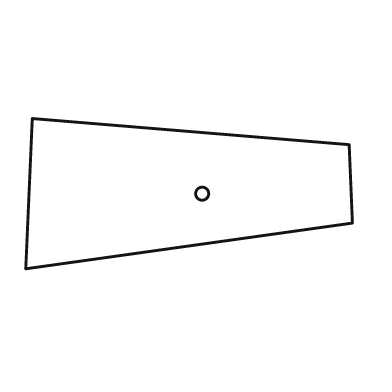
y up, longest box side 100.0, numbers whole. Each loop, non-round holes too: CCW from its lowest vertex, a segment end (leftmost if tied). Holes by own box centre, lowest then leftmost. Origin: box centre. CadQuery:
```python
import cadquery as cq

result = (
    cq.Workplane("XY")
    .moveTo(-50.0, -23.0)
    .lineTo(50.0, -9.0)
    .lineTo(49.0, 15.0)
    .lineTo(-48.0, 23.0)
    .close()
    .moveTo(4.0, 0.0)
    .circle(2.0)
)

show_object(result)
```